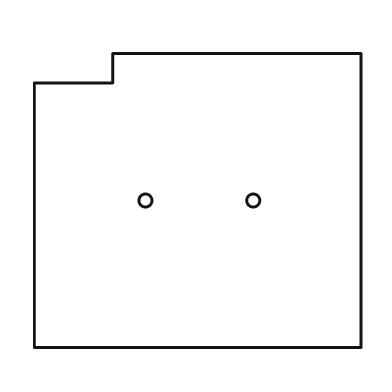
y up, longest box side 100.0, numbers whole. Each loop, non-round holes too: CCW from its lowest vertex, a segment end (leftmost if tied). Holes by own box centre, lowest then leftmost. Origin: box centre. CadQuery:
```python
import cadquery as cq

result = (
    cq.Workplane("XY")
    .moveTo(-50.0, -45.0)
    .lineTo(50.0, -45.0)
    .lineTo(50.0, 45.0)
    .lineTo(-26.0, 45.0)
    .lineTo(-26.0, 36.0)
    .lineTo(-50.0, 36.0)
    .close()
    .moveTo(-16.0, 0.0)
    .circle(2.0)
    .moveTo(17.0, 0.0)
    .circle(2.0)
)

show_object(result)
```